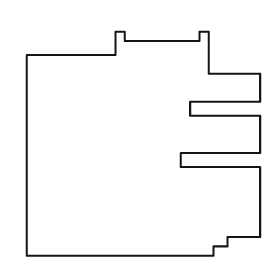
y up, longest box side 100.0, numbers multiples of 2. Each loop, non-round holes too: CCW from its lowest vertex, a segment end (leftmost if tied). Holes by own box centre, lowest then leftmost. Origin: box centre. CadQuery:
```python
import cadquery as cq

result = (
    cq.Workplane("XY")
    .moveTo(-50.0, -48.0)
    .lineTo(30.0, -48.0)
    .lineTo(30.0, -44.0)
    .lineTo(36.0, -44.0)
    .lineTo(36.0, -40.0)
    .lineTo(50.0, -40.0)
    .lineTo(50.0, -10.0)
    .lineTo(16.0, -10.0)
    .lineTo(16.0, -4.0)
    .lineTo(50.0, -4.0)
    .lineTo(50.0, 12.0)
    .lineTo(20.0, 12.0)
    .lineTo(20.0, 18.0)
    .lineTo(50.0, 18.0)
    .lineTo(50.0, 30.0)
    .lineTo(28.0, 30.0)
    .lineTo(28.0, 48.0)
    .lineTo(24.0, 48.0)
    .lineTo(24.0, 44.0)
    .lineTo(-8.0, 44.0)
    .lineTo(-8.0, 48.0)
    .lineTo(-12.0, 48.0)
    .lineTo(-12.0, 38.0)
    .lineTo(-50.0, 38.0)
    .close()
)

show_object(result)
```